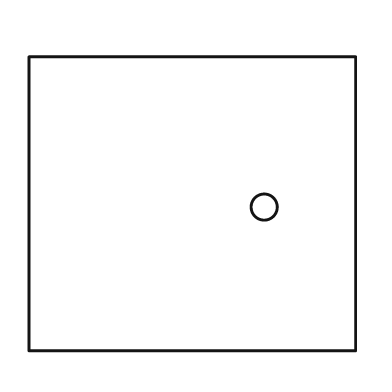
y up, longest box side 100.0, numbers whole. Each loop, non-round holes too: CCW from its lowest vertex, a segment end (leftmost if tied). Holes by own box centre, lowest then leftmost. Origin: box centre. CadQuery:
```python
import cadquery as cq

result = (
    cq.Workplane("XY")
    .moveTo(-50.0, -45.0)
    .lineTo(50.0, -45.0)
    .lineTo(50.0, 45.0)
    .lineTo(-50.0, 45.0)
    .close()
    .moveTo(22.0, -1.0)
    .circle(4.0)
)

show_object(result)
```